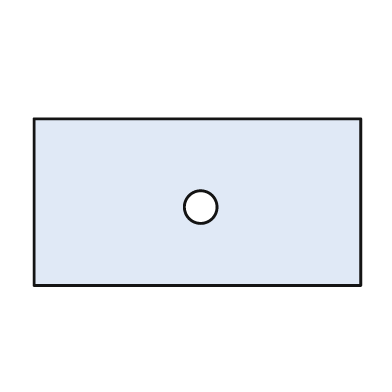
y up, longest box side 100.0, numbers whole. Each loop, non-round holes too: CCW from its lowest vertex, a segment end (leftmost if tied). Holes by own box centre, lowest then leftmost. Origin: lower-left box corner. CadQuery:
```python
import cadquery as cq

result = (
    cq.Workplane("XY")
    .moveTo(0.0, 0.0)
    .lineTo(100.0, 0.0)
    .lineTo(100.0, 51.0)
    .lineTo(0.0, 51.0)
    .close()
    .moveTo(51.0, 24.0)
    .circle(5.0)
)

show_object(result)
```